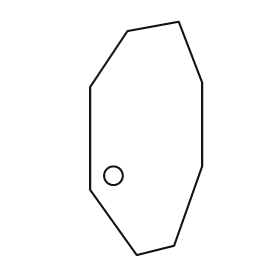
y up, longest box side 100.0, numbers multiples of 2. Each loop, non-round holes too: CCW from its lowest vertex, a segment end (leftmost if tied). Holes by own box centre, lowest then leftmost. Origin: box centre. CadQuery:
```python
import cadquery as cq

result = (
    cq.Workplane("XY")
    .moveTo(-4.0, -50.0)
    .lineTo(12.0, -46.0)
    .lineTo(24.0, -12.0)
    .lineTo(24.0, 24.0)
    .lineTo(14.0, 50.0)
    .lineTo(-8.0, 46.0)
    .lineTo(-24.0, 22.0)
    .lineTo(-24.0, -22.0)
    .close()
    .moveTo(-14.0, -16.0)
    .circle(4.0)
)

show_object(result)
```